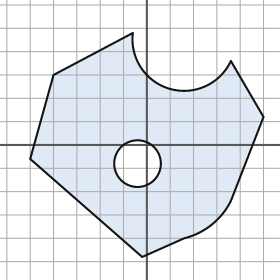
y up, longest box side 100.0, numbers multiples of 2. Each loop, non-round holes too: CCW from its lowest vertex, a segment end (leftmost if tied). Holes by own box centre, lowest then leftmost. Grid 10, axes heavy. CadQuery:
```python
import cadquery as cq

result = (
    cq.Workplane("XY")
    .moveTo(-2.0, -48.0)
    .lineTo(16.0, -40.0)
    .threePointArc((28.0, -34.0), (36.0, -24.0))
    .lineTo(50.0, 12.0)
    .lineTo(36.0, 36.0)
    .threePointArc((10.0, 24.0), (-6.0, 48.0))
    .lineTo(-40.0, 30.0)
    .lineTo(-50.0, -6.0)
    .close()
    .moveTo(-4.0, -8.0)
    .circle(10.0)
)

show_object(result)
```